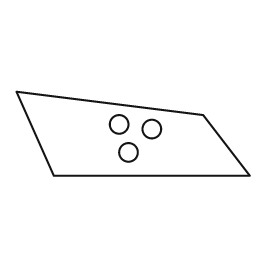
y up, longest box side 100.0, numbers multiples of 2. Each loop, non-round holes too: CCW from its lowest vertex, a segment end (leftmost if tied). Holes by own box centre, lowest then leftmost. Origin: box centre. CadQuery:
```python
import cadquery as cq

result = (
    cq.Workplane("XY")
    .moveTo(-34.0, -18.0)
    .lineTo(50.0, -18.0)
    .lineTo(30.0, 8.0)
    .lineTo(-50.0, 18.0)
    .close()
    .moveTo(-2.0, -8.0)
    .circle(4.0)
    .moveTo(8.0, 2.0)
    .circle(4.0)
    .moveTo(-6.0, 4.0)
    .circle(4.0)
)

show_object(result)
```